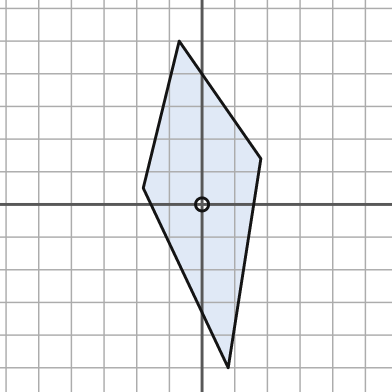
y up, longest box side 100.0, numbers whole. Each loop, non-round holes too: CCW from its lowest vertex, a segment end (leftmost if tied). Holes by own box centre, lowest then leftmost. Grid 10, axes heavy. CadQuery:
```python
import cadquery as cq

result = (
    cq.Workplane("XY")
    .moveTo(8.0, -50.0)
    .lineTo(18.0, 14.0)
    .lineTo(-7.0, 50.0)
    .lineTo(-18.0, 5.0)
    .close()
    .moveTo(0.0, 0.0)
    .circle(2.0)
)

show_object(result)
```